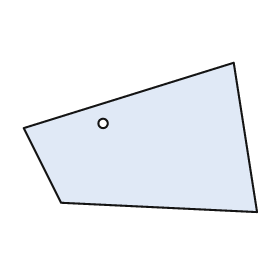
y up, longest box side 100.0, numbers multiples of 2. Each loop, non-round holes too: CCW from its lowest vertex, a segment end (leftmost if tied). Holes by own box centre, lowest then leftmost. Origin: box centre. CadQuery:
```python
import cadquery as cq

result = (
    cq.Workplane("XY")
    .moveTo(50.0, -32.0)
    .lineTo(40.0, 32.0)
    .lineTo(-50.0, 4.0)
    .lineTo(-34.0, -28.0)
    .close()
    .moveTo(-16.0, 6.0)
    .circle(2.0)
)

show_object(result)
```